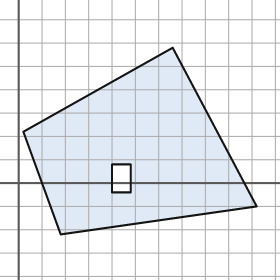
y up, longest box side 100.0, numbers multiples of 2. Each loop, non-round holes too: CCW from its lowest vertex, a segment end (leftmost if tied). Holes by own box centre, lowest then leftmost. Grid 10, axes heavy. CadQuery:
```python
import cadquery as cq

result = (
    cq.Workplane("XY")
    .moveTo(18.0, -22.0)
    .lineTo(102.0, -10.0)
    .lineTo(66.0, 58.0)
    .lineTo(2.0, 22.0)
    .close()
    .moveTo(40.0, -4.0)
    .lineTo(48.0, -4.0)
    .lineTo(48.0, 8.0)
    .lineTo(40.0, 8.0)
    .close()
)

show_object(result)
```